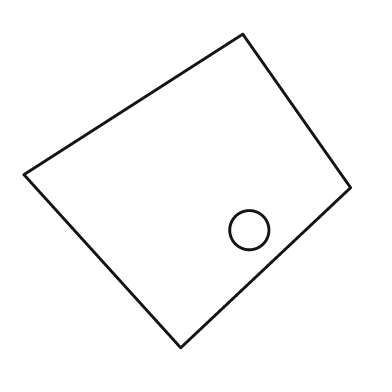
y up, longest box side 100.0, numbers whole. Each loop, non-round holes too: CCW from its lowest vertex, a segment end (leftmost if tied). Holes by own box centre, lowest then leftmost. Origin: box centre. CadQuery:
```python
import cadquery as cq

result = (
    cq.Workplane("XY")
    .moveTo(-2.0, -48.0)
    .lineTo(50.0, 1.0)
    .lineTo(17.0, 48.0)
    .lineTo(-50.0, 5.0)
    .close()
    .moveTo(19.0, -12.0)
    .circle(6.0)
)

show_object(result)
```